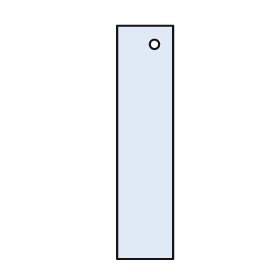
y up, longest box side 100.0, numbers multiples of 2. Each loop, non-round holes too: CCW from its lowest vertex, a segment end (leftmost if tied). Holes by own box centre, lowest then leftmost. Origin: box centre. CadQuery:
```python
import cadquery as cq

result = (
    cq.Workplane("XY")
    .moveTo(-12.0, -50.0)
    .lineTo(12.0, -50.0)
    .lineTo(12.0, 50.0)
    .lineTo(-12.0, 50.0)
    .close()
    .moveTo(4.0, 42.0)
    .circle(2.0)
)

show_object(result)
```